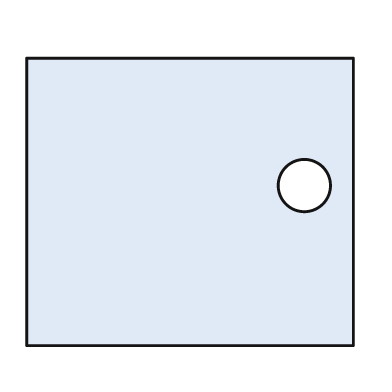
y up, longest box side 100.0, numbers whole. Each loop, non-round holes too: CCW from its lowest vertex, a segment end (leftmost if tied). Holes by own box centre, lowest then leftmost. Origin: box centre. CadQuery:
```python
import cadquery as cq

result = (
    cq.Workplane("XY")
    .moveTo(-50.0, -44.0)
    .lineTo(50.0, -44.0)
    .lineTo(50.0, 44.0)
    .lineTo(-50.0, 44.0)
    .close()
    .moveTo(35.0, 5.0)
    .circle(8.0)
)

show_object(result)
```